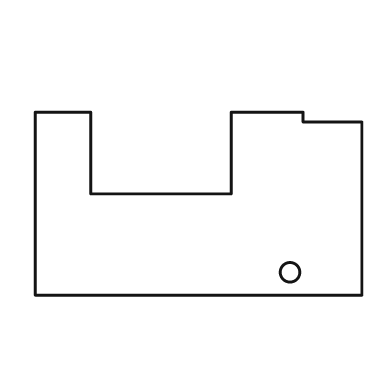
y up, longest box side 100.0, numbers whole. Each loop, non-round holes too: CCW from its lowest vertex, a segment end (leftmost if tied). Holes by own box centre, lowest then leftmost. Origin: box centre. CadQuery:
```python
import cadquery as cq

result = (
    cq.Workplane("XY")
    .moveTo(-50.0, -28.0)
    .lineTo(50.0, -28.0)
    .lineTo(50.0, 25.0)
    .lineTo(32.0, 25.0)
    .lineTo(32.0, 28.0)
    .lineTo(10.0, 28.0)
    .lineTo(10.0, 3.0)
    .lineTo(-33.0, 3.0)
    .lineTo(-33.0, 28.0)
    .lineTo(-50.0, 28.0)
    .close()
    .moveTo(28.0, -21.0)
    .circle(3.0)
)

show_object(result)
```